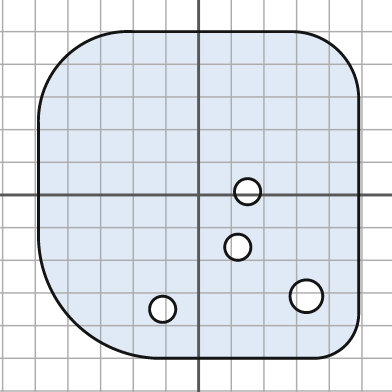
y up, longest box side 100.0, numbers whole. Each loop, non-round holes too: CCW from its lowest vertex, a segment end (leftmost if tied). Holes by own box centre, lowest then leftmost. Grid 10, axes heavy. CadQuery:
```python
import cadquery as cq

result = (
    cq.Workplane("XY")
    .moveTo(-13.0, -50.0)
    .lineTo(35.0, -50.0)
    .threePointArc((45.0, -46.0), (49.0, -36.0))
    .lineTo(49.0, 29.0)
    .threePointArc((43.0, 44.0), (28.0, 50.0))
    .lineTo(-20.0, 50.0)
    .threePointArc((-41.0, 42.0), (-49.0, 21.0))
    .lineTo(-49.0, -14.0)
    .threePointArc((-38.0, -39.0), (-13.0, -50.0))
    .close()
    .moveTo(-11.0, -35.0)
    .circle(4.0)
    .moveTo(33.0, -31.0)
    .circle(5.0)
    .moveTo(12.0, -16.0)
    .circle(4.0)
    .moveTo(15.0, 1.0)
    .circle(4.0)
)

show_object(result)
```